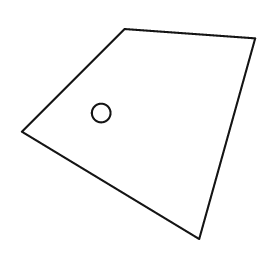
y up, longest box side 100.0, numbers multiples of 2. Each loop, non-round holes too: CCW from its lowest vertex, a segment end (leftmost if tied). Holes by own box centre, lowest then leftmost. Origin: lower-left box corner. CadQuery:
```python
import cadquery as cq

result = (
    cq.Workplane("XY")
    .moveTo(76.0, 0.0)
    .lineTo(100.0, 86.0)
    .lineTo(44.0, 90.0)
    .lineTo(0.0, 46.0)
    .close()
    .moveTo(34.0, 54.0)
    .circle(4.0)
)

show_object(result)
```